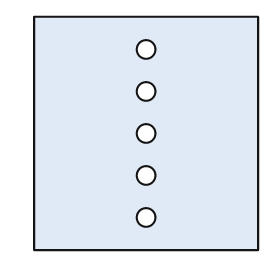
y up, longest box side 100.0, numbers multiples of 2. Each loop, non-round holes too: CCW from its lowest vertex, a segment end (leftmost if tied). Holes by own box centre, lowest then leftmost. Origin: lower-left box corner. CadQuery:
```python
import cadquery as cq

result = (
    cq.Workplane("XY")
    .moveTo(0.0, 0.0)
    .lineTo(96.0, 0.0)
    .lineTo(96.0, 100.0)
    .lineTo(0.0, 100.0)
    .close()
    .moveTo(48.0, 14.0)
    .circle(4.0)
    .moveTo(48.0, 32.0)
    .circle(4.0)
    .moveTo(48.0, 50.0)
    .circle(4.0)
    .moveTo(48.0, 68.0)
    .circle(4.0)
    .moveTo(48.0, 86.0)
    .circle(4.0)
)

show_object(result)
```